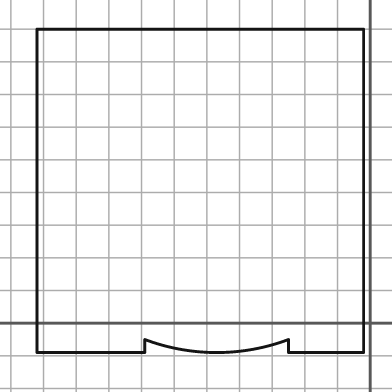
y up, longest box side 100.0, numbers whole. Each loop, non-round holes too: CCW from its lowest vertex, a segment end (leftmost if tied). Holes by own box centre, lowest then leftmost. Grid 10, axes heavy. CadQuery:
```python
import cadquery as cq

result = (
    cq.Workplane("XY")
    .moveTo(-102.0, -9.0)
    .lineTo(-69.0, -9.0)
    .lineTo(-69.0, -5.0)
    .threePointArc((-47.0, -9.0), (-25.0, -5.0))
    .lineTo(-25.0, -9.0)
    .lineTo(-2.0, -9.0)
    .lineTo(-2.0, 90.0)
    .lineTo(-102.0, 90.0)
    .close()
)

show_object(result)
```